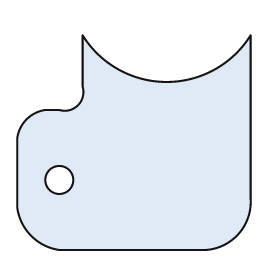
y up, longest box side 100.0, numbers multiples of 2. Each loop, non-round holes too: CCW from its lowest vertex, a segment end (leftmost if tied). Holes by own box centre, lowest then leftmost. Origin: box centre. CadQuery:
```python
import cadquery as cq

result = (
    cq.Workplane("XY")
    .moveTo(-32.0, -46.0)
    .lineTo(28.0, -46.0)
    .threePointArc((44.0, -40.0), (50.0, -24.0))
    .lineTo(50.0, 46.0)
    .threePointArc((14.0, 26.0), (-22.0, 46.0))
    .lineTo(-22.0, 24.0)
    .threePointArc((-24.0, 16.0), (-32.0, 14.0))
    .lineTo(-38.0, 14.0)
    .threePointArc((-46.0, 10.0), (-50.0, 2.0))
    .lineTo(-50.0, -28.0)
    .threePointArc((-44.0, -40.0), (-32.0, -46.0))
    .close()
    .moveTo(-32.0, -16.0)
    .circle(6.0)
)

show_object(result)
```